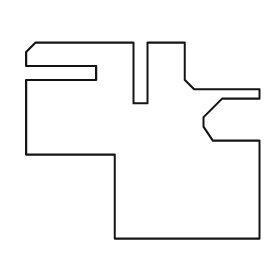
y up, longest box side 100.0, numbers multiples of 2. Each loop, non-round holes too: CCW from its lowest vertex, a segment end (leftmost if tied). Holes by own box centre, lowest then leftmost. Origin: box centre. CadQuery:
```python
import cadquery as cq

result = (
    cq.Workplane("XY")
    .moveTo(-12.0, -42.0)
    .lineTo(50.0, -42.0)
    .lineTo(50.0, 0.0)
    .lineTo(30.0, 0.0)
    .lineTo(26.0, 6.0)
    .lineTo(26.0, 10.0)
    .lineTo(34.0, 18.0)
    .lineTo(50.0, 18.0)
    .lineTo(50.0, 22.0)
    .lineTo(22.0, 22.0)
    .lineTo(18.0, 26.0)
    .lineTo(18.0, 42.0)
    .lineTo(2.0, 42.0)
    .lineTo(2.0, 16.0)
    .lineTo(-4.0, 16.0)
    .lineTo(-4.0, 42.0)
    .lineTo(-46.0, 42.0)
    .lineTo(-50.0, 38.0)
    .lineTo(-50.0, 32.0)
    .lineTo(-20.0, 32.0)
    .lineTo(-20.0, 26.0)
    .lineTo(-50.0, 26.0)
    .lineTo(-50.0, -6.0)
    .lineTo(-12.0, -6.0)
    .close()
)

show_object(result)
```